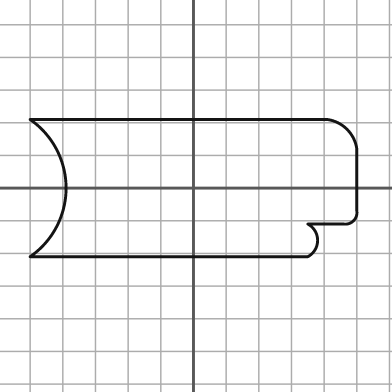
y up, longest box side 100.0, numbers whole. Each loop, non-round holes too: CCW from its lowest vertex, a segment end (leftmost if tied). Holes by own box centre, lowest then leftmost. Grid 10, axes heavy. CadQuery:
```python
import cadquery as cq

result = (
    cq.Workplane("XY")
    .moveTo(-50.0, -21.0)
    .lineTo(35.0, -21.0)
    .threePointArc((38.0, -16.0), (35.0, -11.0))
    .lineTo(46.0, -11.0)
    .threePointArc((49.0, -10.0), (50.0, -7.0))
    .lineTo(50.0, 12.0)
    .threePointArc((47.0, 18.0), (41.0, 21.0))
    .lineTo(-50.0, 21.0)
    .threePointArc((-39.0, 0.0), (-50.0, -21.0))
    .close()
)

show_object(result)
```